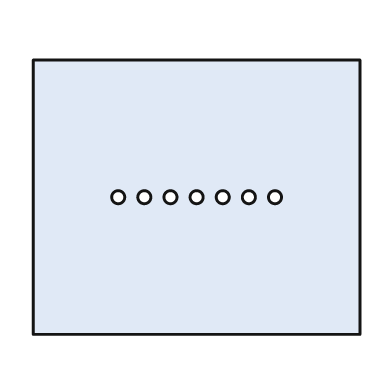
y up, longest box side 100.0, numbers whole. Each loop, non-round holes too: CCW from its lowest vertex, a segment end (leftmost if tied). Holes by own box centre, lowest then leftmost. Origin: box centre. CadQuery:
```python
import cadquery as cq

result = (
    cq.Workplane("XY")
    .moveTo(-50.0, -42.0)
    .lineTo(50.0, -42.0)
    .lineTo(50.0, 42.0)
    .lineTo(-50.0, 42.0)
    .close()
    .moveTo(-24.0, 0.0)
    .circle(2.0)
    .moveTo(-16.0, 0.0)
    .circle(2.0)
    .moveTo(-8.0, 0.0)
    .circle(2.0)
    .moveTo(0.0, 0.0)
    .circle(2.0)
    .moveTo(8.0, 0.0)
    .circle(2.0)
    .moveTo(16.0, 0.0)
    .circle(2.0)
    .moveTo(24.0, 0.0)
    .circle(2.0)
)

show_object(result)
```